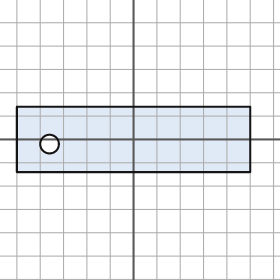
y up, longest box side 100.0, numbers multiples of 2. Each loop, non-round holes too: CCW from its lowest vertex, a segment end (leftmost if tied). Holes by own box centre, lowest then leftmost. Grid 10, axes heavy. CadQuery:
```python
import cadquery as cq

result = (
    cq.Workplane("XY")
    .moveTo(-50.0, -14.0)
    .lineTo(50.0, -14.0)
    .lineTo(50.0, 14.0)
    .lineTo(-50.0, 14.0)
    .close()
    .moveTo(-36.0, -2.0)
    .circle(4.0)
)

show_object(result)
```